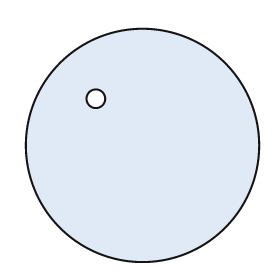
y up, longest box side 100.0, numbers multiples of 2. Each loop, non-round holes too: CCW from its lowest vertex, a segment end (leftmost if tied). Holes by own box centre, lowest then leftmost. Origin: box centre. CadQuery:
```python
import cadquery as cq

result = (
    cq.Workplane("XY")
    .moveTo(0.0, 0.0)
    .circle(50.0)
    .moveTo(-20.0, 20.0)
    .circle(4.0)
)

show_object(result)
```